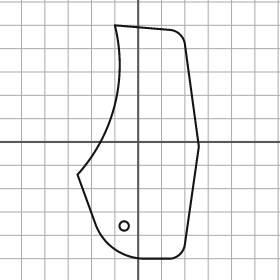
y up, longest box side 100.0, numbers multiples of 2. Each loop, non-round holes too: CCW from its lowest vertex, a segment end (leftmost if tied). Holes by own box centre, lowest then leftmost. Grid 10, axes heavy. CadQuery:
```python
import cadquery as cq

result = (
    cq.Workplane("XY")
    .moveTo(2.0, -50.0)
    .lineTo(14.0, -50.0)
    .threePointArc((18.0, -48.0), (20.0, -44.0))
    .lineTo(26.0, -2.0)
    .lineTo(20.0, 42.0)
    .threePointArc((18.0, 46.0), (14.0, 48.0))
    .lineTo(-10.0, 50.0)
    .threePointArc((-10.0, 16.0), (-26.0, -14.0))
    .lineTo(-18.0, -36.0)
    .threePointArc((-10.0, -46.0), (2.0, -50.0))
    .close()
    .moveTo(-6.0, -36.0)
    .circle(2.0)
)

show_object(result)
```